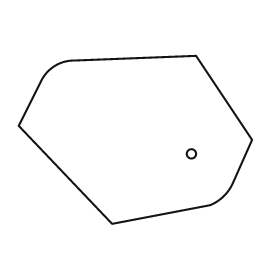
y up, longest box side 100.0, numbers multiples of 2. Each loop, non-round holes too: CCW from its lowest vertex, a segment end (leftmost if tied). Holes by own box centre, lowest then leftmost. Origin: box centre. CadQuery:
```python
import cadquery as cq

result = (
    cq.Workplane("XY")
    .moveTo(-10.0, -36.0)
    .lineTo(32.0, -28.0)
    .threePointArc((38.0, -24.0), (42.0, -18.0))
    .lineTo(50.0, 0.0)
    .lineTo(26.0, 36.0)
    .lineTo(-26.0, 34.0)
    .threePointArc((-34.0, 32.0), (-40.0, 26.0))
    .lineTo(-50.0, 6.0)
    .close()
    .moveTo(24.0, -6.0)
    .circle(2.0)
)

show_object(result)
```